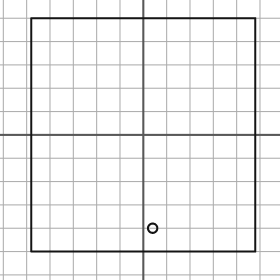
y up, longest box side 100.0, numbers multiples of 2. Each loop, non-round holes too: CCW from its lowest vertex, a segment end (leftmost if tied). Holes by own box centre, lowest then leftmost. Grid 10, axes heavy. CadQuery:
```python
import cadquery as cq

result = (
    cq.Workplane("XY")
    .moveTo(-48.0, -50.0)
    .lineTo(48.0, -50.0)
    .lineTo(48.0, 50.0)
    .lineTo(-48.0, 50.0)
    .close()
    .moveTo(4.0, -40.0)
    .circle(2.0)
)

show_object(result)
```